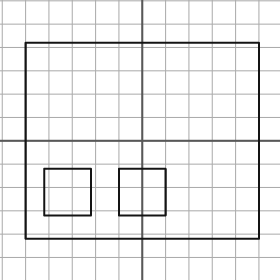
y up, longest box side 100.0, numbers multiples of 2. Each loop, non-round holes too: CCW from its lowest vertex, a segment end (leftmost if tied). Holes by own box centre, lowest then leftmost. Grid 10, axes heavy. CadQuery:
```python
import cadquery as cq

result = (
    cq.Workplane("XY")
    .moveTo(-50.0, -42.0)
    .lineTo(50.0, -42.0)
    .lineTo(50.0, 42.0)
    .lineTo(-50.0, 42.0)
    .close()
    .moveTo(-42.0, -32.0)
    .lineTo(-22.0, -32.0)
    .lineTo(-22.0, -12.0)
    .lineTo(-42.0, -12.0)
    .close()
    .moveTo(-10.0, -32.0)
    .lineTo(10.0, -32.0)
    .lineTo(10.0, -12.0)
    .lineTo(-10.0, -12.0)
    .close()
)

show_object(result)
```